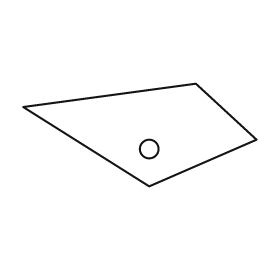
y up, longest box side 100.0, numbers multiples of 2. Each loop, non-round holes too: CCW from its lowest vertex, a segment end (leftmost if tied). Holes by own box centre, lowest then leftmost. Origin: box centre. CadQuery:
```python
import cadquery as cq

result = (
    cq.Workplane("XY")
    .moveTo(4.0, -22.0)
    .lineTo(50.0, -2.0)
    .lineTo(24.0, 22.0)
    .lineTo(-50.0, 12.0)
    .close()
    .moveTo(4.0, -6.0)
    .circle(4.0)
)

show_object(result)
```